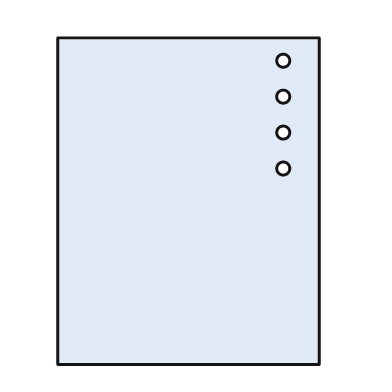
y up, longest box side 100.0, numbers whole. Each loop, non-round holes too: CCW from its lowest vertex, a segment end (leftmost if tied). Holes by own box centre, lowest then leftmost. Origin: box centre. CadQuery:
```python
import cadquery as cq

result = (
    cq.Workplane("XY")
    .moveTo(-40.0, -50.0)
    .lineTo(40.0, -50.0)
    .lineTo(40.0, 50.0)
    .lineTo(-40.0, 50.0)
    .close()
    .moveTo(29.0, 10.0)
    .circle(2.0)
    .moveTo(29.0, 21.0)
    .circle(2.0)
    .moveTo(29.0, 32.0)
    .circle(2.0)
    .moveTo(29.0, 43.0)
    .circle(2.0)
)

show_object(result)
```